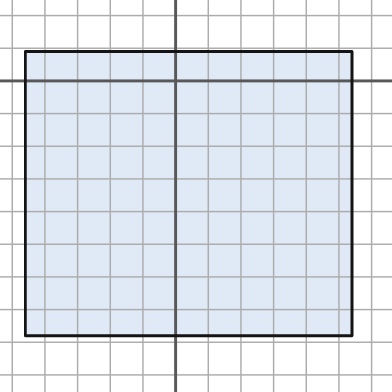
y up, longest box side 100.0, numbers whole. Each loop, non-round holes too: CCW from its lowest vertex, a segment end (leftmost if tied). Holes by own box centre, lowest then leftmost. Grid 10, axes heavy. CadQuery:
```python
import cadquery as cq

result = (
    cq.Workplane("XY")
    .moveTo(-46.0, -78.0)
    .lineTo(54.0, -78.0)
    .lineTo(54.0, 9.0)
    .lineTo(-46.0, 9.0)
    .close()
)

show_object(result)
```